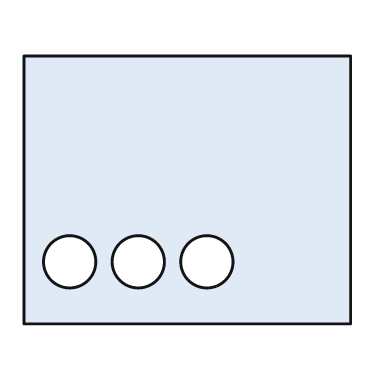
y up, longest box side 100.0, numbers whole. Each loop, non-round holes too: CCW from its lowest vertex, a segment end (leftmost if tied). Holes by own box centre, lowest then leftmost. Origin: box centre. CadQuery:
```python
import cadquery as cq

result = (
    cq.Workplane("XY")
    .moveTo(-50.0, -41.0)
    .lineTo(50.0, -41.0)
    .lineTo(50.0, 41.0)
    .lineTo(-50.0, 41.0)
    .close()
    .moveTo(-36.0, -22.0)
    .circle(8.0)
    .moveTo(-15.0, -22.0)
    .circle(8.0)
    .moveTo(6.0, -22.0)
    .circle(8.0)
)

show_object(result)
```